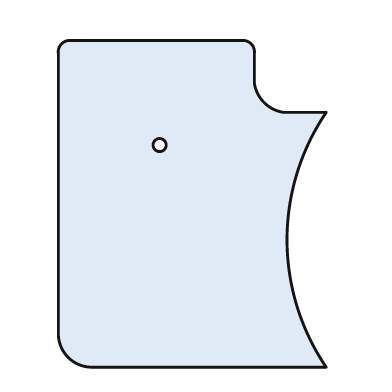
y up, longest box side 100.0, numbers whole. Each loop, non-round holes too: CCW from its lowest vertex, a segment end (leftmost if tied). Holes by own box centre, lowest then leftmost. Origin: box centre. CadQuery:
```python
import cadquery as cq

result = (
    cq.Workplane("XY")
    .moveTo(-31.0, -50.0)
    .lineTo(41.0, -50.0)
    .threePointArc((29.0, -11.0), (41.0, 28.0))
    .lineTo(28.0, 28.0)
    .threePointArc((22.0, 31.0), (19.0, 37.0))
    .lineTo(19.0, 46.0)
    .threePointArc((18.0, 49.0), (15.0, 50.0))
    .lineTo(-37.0, 50.0)
    .threePointArc((-40.0, 49.0), (-41.0, 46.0))
    .lineTo(-41.0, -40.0)
    .threePointArc((-38.0, -47.0), (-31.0, -50.0))
    .close()
    .moveTo(-10.0, 18.0)
    .circle(2.0)
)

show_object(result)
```